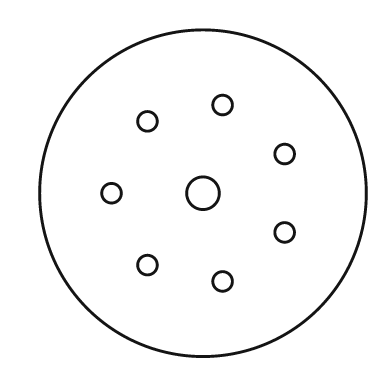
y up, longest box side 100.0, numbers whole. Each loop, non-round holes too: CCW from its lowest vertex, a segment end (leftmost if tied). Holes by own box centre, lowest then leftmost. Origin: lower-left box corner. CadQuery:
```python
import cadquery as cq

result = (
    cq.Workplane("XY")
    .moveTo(50.0, 50.0)
    .circle(50.0)
    .moveTo(56.0, 23.0)
    .circle(3.0)
    .moveTo(33.0, 28.0)
    .circle(3.0)
    .moveTo(75.0, 38.0)
    .circle(3.0)
    .moveTo(22.0, 50.0)
    .circle(3.0)
    .moveTo(50.0, 50.0)
    .circle(5.0)
    .moveTo(75.0, 62.0)
    .circle(3.0)
    .moveTo(33.0, 72.0)
    .circle(3.0)
    .moveTo(56.0, 77.0)
    .circle(3.0)
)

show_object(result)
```